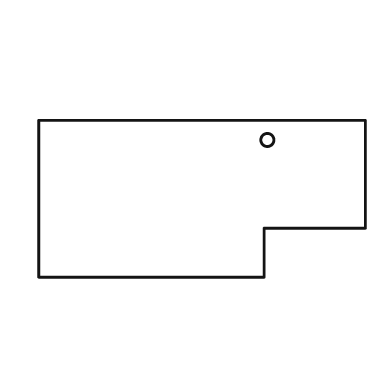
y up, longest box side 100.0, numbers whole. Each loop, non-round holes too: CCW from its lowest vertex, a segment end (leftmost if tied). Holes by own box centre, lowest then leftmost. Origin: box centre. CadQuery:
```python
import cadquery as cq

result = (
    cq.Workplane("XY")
    .moveTo(-50.0, -24.0)
    .lineTo(19.0, -24.0)
    .lineTo(19.0, -9.0)
    .lineTo(50.0, -9.0)
    .lineTo(50.0, 24.0)
    .lineTo(-50.0, 24.0)
    .close()
    .moveTo(20.0, 18.0)
    .circle(2.0)
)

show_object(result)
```